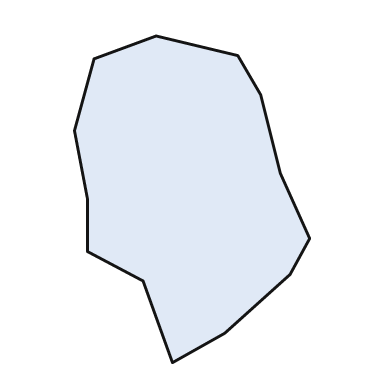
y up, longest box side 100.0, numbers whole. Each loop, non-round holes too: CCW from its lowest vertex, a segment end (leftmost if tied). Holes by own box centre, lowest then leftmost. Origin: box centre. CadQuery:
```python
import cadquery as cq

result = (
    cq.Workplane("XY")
    .moveTo(-6.0, -50.0)
    .lineTo(10.0, -41.0)
    .lineTo(30.0, -23.0)
    .lineTo(36.0, -12.0)
    .lineTo(27.0, 8.0)
    .lineTo(21.0, 32.0)
    .lineTo(14.0, 44.0)
    .lineTo(-11.0, 50.0)
    .lineTo(-30.0, 43.0)
    .lineTo(-36.0, 21.0)
    .lineTo(-32.0, 0.0)
    .lineTo(-32.0, -16.0)
    .lineTo(-15.0, -25.0)
    .close()
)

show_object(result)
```